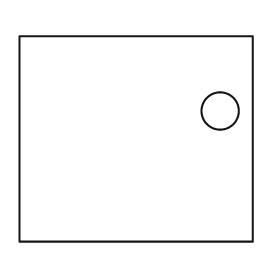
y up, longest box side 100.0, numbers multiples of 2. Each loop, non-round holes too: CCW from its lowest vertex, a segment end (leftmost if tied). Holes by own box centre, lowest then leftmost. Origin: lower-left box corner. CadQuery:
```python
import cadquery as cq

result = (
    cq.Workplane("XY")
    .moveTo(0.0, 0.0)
    .lineTo(100.0, 0.0)
    .lineTo(100.0, 88.0)
    .lineTo(0.0, 88.0)
    .close()
    .moveTo(86.0, 56.0)
    .circle(8.0)
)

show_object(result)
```